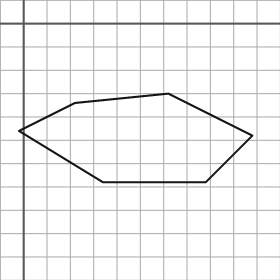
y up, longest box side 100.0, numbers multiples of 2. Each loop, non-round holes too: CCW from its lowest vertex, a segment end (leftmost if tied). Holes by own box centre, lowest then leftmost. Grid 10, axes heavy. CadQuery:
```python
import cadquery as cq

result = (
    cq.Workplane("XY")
    .moveTo(34.0, -68.0)
    .lineTo(78.0, -68.0)
    .lineTo(98.0, -48.0)
    .lineTo(62.0, -30.0)
    .lineTo(22.0, -34.0)
    .lineTo(-2.0, -46.0)
    .close()
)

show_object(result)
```